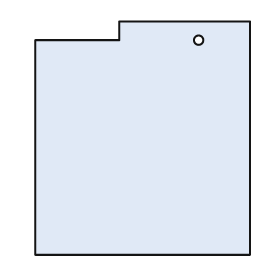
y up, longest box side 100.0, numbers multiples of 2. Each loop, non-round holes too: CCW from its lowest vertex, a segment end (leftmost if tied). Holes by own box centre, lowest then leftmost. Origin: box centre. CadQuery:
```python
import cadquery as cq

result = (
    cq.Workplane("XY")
    .moveTo(-46.0, -50.0)
    .lineTo(46.0, -50.0)
    .lineTo(46.0, 50.0)
    .lineTo(-10.0, 50.0)
    .lineTo(-10.0, 42.0)
    .lineTo(-46.0, 42.0)
    .close()
    .moveTo(24.0, 42.0)
    .circle(2.0)
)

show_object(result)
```